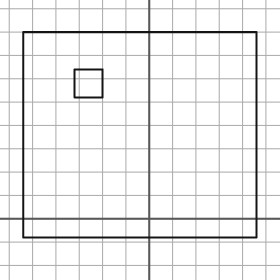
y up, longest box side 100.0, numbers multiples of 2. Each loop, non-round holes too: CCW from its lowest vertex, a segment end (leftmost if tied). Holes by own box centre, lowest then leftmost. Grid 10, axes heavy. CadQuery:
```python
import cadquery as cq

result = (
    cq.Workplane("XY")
    .moveTo(-54.0, -8.0)
    .lineTo(46.0, -8.0)
    .lineTo(46.0, 80.0)
    .lineTo(-54.0, 80.0)
    .close()
    .moveTo(-32.0, 52.0)
    .lineTo(-20.0, 52.0)
    .lineTo(-20.0, 64.0)
    .lineTo(-32.0, 64.0)
    .close()
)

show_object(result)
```